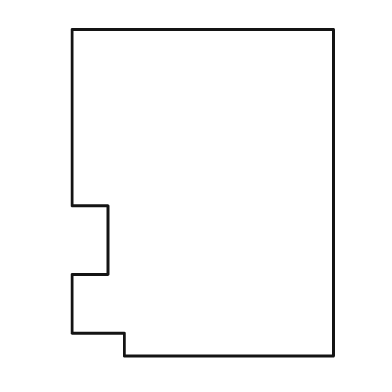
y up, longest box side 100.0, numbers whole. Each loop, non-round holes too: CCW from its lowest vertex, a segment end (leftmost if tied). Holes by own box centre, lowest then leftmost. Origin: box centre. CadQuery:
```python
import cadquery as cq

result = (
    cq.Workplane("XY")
    .moveTo(-24.0, -50.0)
    .lineTo(40.0, -50.0)
    .lineTo(40.0, 50.0)
    .lineTo(-40.0, 50.0)
    .lineTo(-40.0, -4.0)
    .lineTo(-29.0, -4.0)
    .lineTo(-29.0, -25.0)
    .lineTo(-40.0, -25.0)
    .lineTo(-40.0, -43.0)
    .lineTo(-24.0, -43.0)
    .close()
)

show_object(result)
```